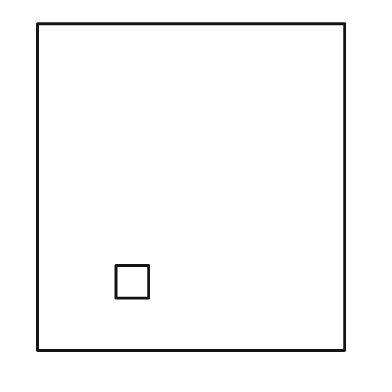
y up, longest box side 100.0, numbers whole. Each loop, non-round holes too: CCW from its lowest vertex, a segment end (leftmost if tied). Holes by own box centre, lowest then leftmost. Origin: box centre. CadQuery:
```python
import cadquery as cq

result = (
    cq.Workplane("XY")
    .moveTo(-47.0, -50.0)
    .lineTo(47.0, -50.0)
    .lineTo(47.0, 50.0)
    .lineTo(-47.0, 50.0)
    .close()
    .moveTo(-23.0, -34.0)
    .lineTo(-13.0, -34.0)
    .lineTo(-13.0, -24.0)
    .lineTo(-23.0, -24.0)
    .close()
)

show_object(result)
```